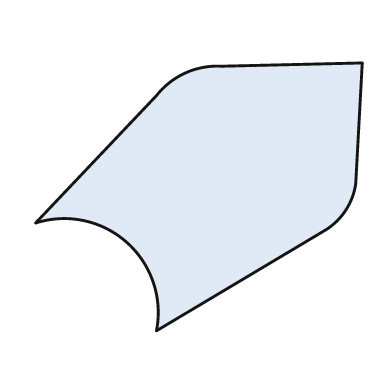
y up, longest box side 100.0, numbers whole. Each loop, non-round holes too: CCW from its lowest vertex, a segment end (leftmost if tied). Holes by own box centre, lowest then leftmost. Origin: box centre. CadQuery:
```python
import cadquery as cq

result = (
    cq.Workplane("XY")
    .moveTo(-13.0, -41.0)
    .lineTo(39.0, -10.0)
    .threePointArc((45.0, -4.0), (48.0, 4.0))
    .lineTo(50.0, 41.0)
    .lineTo(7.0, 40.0)
    .threePointArc((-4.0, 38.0), (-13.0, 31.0))
    .lineTo(-50.0, -8.0)
    .threePointArc((-22.0, -14.0), (-13.0, -41.0))
    .close()
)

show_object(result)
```